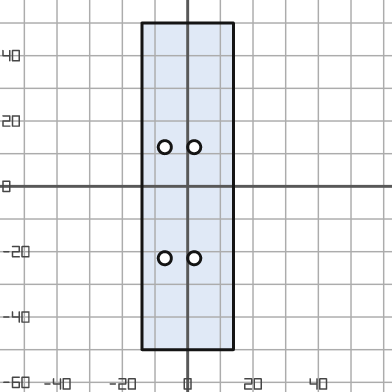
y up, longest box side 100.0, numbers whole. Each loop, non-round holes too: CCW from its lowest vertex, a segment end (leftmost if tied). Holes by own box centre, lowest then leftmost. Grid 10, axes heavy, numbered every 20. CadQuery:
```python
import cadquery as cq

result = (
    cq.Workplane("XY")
    .moveTo(-14.0, -50.0)
    .lineTo(14.0, -50.0)
    .lineTo(14.0, 50.0)
    .lineTo(-14.0, 50.0)
    .close()
    .moveTo(-7.0, -22.0)
    .circle(2.0)
    .moveTo(2.0, -22.0)
    .circle(2.0)
    .moveTo(-7.0, 12.0)
    .circle(2.0)
    .moveTo(2.0, 12.0)
    .circle(2.0)
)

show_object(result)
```